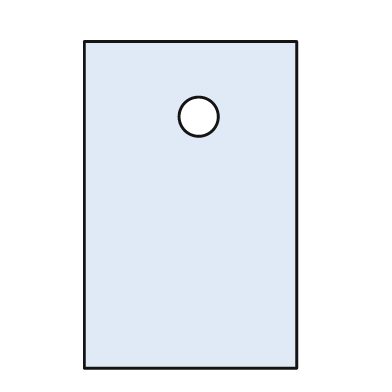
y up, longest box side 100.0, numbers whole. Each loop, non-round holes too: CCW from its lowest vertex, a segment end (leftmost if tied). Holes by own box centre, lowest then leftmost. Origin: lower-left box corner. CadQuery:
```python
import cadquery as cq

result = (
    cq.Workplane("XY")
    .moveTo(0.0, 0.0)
    .lineTo(65.0, 0.0)
    .lineTo(65.0, 100.0)
    .lineTo(0.0, 100.0)
    .close()
    .moveTo(35.0, 77.0)
    .circle(6.0)
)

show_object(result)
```